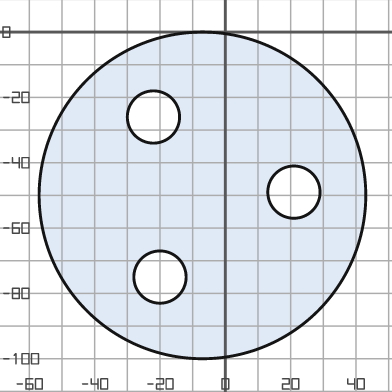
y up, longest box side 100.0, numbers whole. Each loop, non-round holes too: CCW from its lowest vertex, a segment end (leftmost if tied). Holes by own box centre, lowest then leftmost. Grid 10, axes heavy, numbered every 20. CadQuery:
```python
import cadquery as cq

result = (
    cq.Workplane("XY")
    .moveTo(-7.0, -50.0)
    .circle(50.0)
    .moveTo(-20.0, -75.0)
    .circle(8.0)
    .moveTo(21.0, -49.0)
    .circle(8.0)
    .moveTo(-22.0, -26.0)
    .circle(8.0)
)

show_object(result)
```